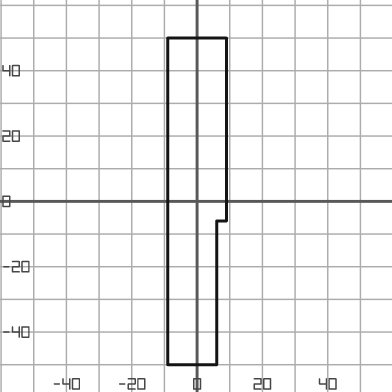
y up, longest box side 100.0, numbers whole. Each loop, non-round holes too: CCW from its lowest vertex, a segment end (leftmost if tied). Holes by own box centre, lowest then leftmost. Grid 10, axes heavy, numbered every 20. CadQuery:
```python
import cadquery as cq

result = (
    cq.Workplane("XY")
    .moveTo(-9.0, -50.0)
    .lineTo(6.0, -50.0)
    .lineTo(6.0, -6.0)
    .lineTo(9.0, -6.0)
    .lineTo(9.0, 50.0)
    .lineTo(-9.0, 50.0)
    .close()
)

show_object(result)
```